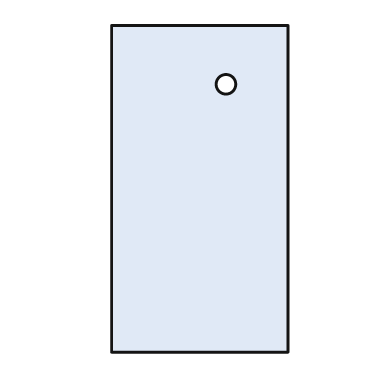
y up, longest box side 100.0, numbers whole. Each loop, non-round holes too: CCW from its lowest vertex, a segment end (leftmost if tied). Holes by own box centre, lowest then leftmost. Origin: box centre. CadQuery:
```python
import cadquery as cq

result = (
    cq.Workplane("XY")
    .moveTo(-27.0, -50.0)
    .lineTo(27.0, -50.0)
    .lineTo(27.0, 50.0)
    .lineTo(-27.0, 50.0)
    .close()
    .moveTo(8.0, 32.0)
    .circle(3.0)
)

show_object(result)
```